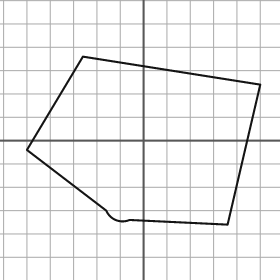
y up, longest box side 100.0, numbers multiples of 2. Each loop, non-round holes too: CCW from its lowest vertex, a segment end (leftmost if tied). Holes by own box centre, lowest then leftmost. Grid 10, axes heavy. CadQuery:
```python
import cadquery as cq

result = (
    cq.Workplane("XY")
    .moveTo(36.0, -36.0)
    .lineTo(50.0, 24.0)
    .lineTo(-26.0, 36.0)
    .lineTo(-50.0, -4.0)
    .lineTo(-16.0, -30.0)
    .threePointArc((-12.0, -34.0), (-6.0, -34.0))
    .close()
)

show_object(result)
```